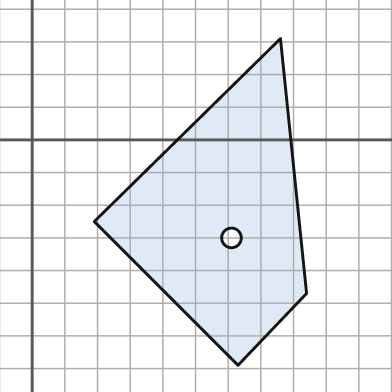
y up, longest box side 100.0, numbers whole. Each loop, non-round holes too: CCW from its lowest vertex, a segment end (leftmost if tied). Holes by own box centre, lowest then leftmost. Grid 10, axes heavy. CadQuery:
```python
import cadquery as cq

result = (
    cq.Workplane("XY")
    .moveTo(63.0, -69.0)
    .lineTo(84.0, -47.0)
    .lineTo(76.0, 31.0)
    .lineTo(19.0, -25.0)
    .close()
    .moveTo(61.0, -30.0)
    .circle(3.0)
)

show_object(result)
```